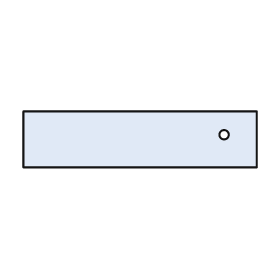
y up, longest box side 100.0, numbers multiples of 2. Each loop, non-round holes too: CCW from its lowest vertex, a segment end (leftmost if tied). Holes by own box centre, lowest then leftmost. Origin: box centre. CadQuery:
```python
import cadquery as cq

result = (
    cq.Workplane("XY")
    .moveTo(-50.0, -12.0)
    .lineTo(50.0, -12.0)
    .lineTo(50.0, 12.0)
    .lineTo(-50.0, 12.0)
    .close()
    .moveTo(36.0, 2.0)
    .circle(2.0)
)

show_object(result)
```